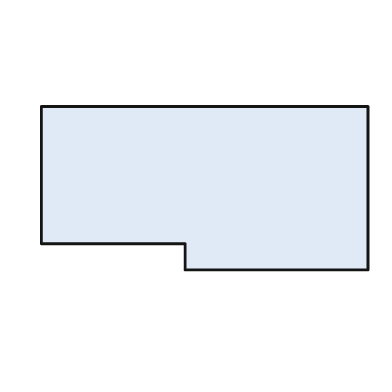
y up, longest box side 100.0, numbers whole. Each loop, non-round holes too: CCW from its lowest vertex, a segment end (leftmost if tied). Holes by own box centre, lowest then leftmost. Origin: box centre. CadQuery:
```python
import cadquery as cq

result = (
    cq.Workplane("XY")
    .moveTo(-6.0, -25.0)
    .lineTo(50.0, -25.0)
    .lineTo(50.0, 25.0)
    .lineTo(-50.0, 25.0)
    .lineTo(-50.0, -17.0)
    .lineTo(-6.0, -17.0)
    .close()
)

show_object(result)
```